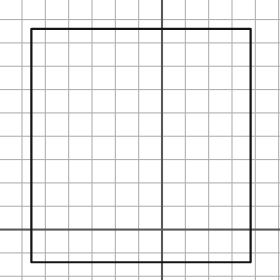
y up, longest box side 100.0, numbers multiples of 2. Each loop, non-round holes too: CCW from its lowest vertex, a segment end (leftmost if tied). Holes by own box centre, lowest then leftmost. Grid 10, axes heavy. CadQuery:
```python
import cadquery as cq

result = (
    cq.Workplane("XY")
    .moveTo(-56.0, -14.0)
    .lineTo(38.0, -14.0)
    .lineTo(38.0, 86.0)
    .lineTo(-56.0, 86.0)
    .close()
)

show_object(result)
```